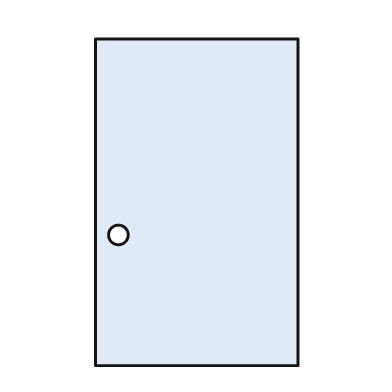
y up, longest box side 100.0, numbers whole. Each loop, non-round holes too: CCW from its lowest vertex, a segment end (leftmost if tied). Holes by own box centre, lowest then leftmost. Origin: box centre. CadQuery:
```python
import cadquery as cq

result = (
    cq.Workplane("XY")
    .moveTo(-31.0, -50.0)
    .lineTo(31.0, -50.0)
    .lineTo(31.0, 50.0)
    .lineTo(-31.0, 50.0)
    .close()
    .moveTo(-24.0, -10.0)
    .circle(3.0)
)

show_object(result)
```